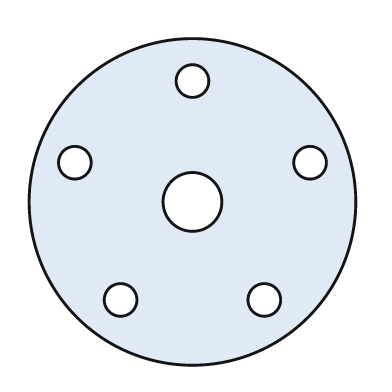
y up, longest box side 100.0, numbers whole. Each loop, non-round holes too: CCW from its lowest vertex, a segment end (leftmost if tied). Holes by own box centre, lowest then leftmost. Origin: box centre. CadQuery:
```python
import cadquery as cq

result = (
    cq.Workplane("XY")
    .moveTo(0.0, 0.0)
    .circle(50.0)
    .moveTo(-22.0, -30.0)
    .circle(5.0)
    .moveTo(22.0, -30.0)
    .circle(5.0)
    .moveTo(0.0, 0.0)
    .circle(9.0)
    .moveTo(-36.0, 12.0)
    .circle(5.0)
    .moveTo(36.0, 12.0)
    .circle(5.0)
    .moveTo(0.0, 37.0)
    .circle(5.0)
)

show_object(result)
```